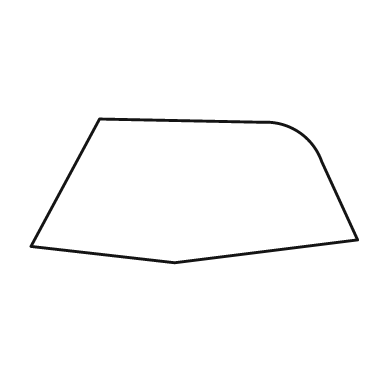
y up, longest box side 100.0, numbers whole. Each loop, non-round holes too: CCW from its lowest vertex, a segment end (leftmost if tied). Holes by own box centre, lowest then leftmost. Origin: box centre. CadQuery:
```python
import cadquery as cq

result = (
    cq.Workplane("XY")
    .moveTo(-6.0, -22.0)
    .lineTo(50.0, -15.0)
    .lineTo(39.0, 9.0)
    .threePointArc((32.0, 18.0), (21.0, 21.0))
    .lineTo(-29.0, 22.0)
    .lineTo(-50.0, -17.0)
    .close()
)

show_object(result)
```